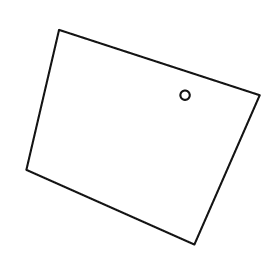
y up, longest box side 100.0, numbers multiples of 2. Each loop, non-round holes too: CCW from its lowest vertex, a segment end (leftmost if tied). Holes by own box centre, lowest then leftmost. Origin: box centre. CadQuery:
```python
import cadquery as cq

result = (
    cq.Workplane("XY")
    .moveTo(22.0, -46.0)
    .lineTo(50.0, 18.0)
    .lineTo(-36.0, 46.0)
    .lineTo(-50.0, -14.0)
    .close()
    .moveTo(18.0, 18.0)
    .circle(2.0)
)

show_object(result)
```